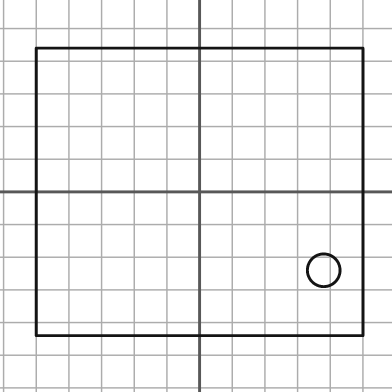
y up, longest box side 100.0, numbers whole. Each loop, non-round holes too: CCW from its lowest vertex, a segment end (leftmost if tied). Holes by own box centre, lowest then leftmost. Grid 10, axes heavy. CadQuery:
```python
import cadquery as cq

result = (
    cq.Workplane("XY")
    .moveTo(-50.0, -44.0)
    .lineTo(50.0, -44.0)
    .lineTo(50.0, 44.0)
    .lineTo(-50.0, 44.0)
    .close()
    .moveTo(38.0, -24.0)
    .circle(5.0)
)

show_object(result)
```